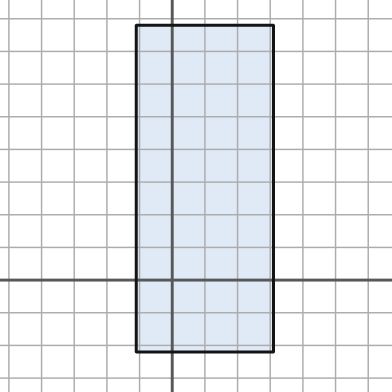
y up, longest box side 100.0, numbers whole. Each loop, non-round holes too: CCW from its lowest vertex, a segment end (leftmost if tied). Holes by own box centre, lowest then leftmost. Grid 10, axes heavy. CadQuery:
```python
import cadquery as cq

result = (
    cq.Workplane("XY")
    .moveTo(-11.0, -22.0)
    .lineTo(31.0, -22.0)
    .lineTo(31.0, 78.0)
    .lineTo(-11.0, 78.0)
    .close()
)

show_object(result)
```